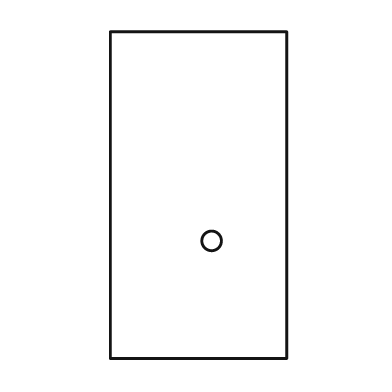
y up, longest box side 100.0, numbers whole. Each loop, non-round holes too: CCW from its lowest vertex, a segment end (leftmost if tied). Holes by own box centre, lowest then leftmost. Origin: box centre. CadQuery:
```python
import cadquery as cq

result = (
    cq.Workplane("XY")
    .moveTo(-27.0, -50.0)
    .lineTo(27.0, -50.0)
    .lineTo(27.0, 50.0)
    .lineTo(-27.0, 50.0)
    .close()
    .moveTo(4.0, -14.0)
    .circle(3.0)
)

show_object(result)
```